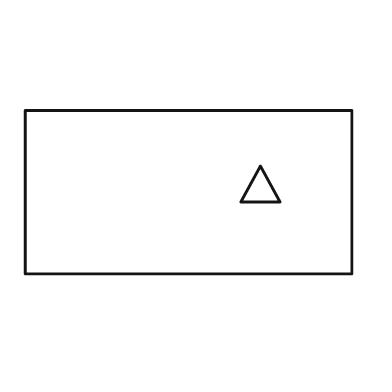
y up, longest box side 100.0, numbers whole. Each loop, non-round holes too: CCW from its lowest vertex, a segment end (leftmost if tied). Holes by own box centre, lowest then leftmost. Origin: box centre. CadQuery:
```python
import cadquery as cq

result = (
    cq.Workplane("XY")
    .moveTo(-50.0, -25.0)
    .lineTo(50.0, -25.0)
    .lineTo(50.0, 25.0)
    .lineTo(-50.0, 25.0)
    .close()
    .moveTo(16.0, -3.0)
    .lineTo(28.0, -3.0)
    .lineTo(22.0, 8.0)
    .close()
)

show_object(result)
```